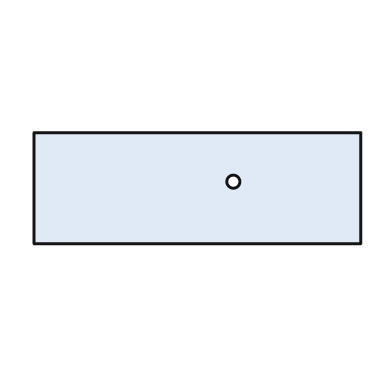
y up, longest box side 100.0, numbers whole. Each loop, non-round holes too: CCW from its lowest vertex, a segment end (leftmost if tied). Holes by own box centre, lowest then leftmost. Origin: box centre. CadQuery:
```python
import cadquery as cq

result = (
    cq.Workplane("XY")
    .moveTo(-50.0, -17.0)
    .lineTo(50.0, -17.0)
    .lineTo(50.0, 17.0)
    .lineTo(-50.0, 17.0)
    .close()
    .moveTo(11.0, 2.0)
    .circle(2.0)
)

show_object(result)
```